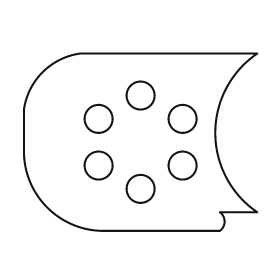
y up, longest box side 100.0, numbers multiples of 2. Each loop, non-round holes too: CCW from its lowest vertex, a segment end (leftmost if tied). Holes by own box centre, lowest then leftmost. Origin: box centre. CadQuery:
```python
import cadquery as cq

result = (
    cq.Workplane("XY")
    .moveTo(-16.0, -38.0)
    .lineTo(34.0, -38.0)
    .threePointArc((36.0, -34.0), (34.0, -30.0))
    .lineTo(50.0, -30.0)
    .threePointArc((32.0, 4.0), (50.0, 38.0))
    .lineTo(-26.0, 38.0)
    .threePointArc((-42.0, 30.0), (-50.0, 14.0))
    .lineTo(-50.0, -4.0)
    .threePointArc((-40.0, -28.0), (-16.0, -38.0))
    .close()
    .moveTo(0.0, -20.0)
    .circle(6.0)
    .moveTo(-18.0, -10.0)
    .circle(6.0)
    .moveTo(18.0, -10.0)
    .circle(6.0)
    .moveTo(-18.0, 10.0)
    .circle(6.0)
    .moveTo(18.0, 10.0)
    .circle(6.0)
    .moveTo(0.0, 20.0)
    .circle(6.0)
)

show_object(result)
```